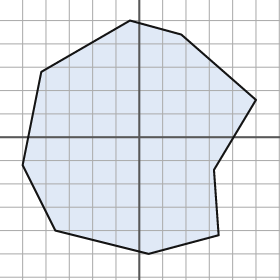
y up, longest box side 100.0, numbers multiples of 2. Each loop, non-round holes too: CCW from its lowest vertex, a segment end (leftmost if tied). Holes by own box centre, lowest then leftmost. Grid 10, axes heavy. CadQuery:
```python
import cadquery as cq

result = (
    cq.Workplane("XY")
    .moveTo(4.0, -50.0)
    .lineTo(34.0, -42.0)
    .lineTo(32.0, -14.0)
    .lineTo(50.0, 16.0)
    .lineTo(18.0, 44.0)
    .lineTo(-4.0, 50.0)
    .lineTo(-42.0, 28.0)
    .lineTo(-50.0, -12.0)
    .lineTo(-36.0, -40.0)
    .close()
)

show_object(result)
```